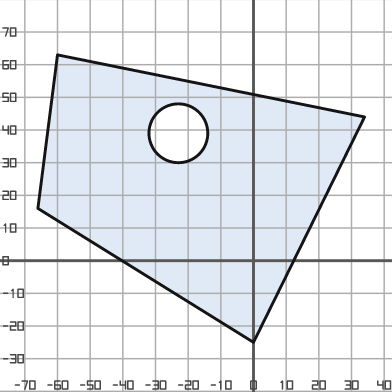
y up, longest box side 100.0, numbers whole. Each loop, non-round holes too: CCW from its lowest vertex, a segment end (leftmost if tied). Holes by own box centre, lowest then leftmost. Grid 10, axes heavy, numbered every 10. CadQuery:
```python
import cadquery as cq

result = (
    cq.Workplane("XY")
    .moveTo(0.0, -25.0)
    .lineTo(34.0, 44.0)
    .lineTo(-60.0, 63.0)
    .lineTo(-66.0, 16.0)
    .close()
    .moveTo(-23.0, 39.0)
    .circle(9.0)
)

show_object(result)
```